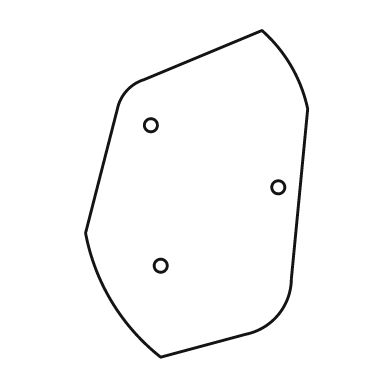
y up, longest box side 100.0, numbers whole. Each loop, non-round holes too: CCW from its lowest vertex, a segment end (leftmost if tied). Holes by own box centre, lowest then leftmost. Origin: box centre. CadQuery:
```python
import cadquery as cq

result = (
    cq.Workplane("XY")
    .moveTo(-11.0, -50.0)
    .lineTo(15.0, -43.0)
    .threePointArc((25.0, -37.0), (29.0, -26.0))
    .lineTo(34.0, 26.0)
    .threePointArc((29.0, 39.0), (20.0, 50.0))
    .lineTo(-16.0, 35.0)
    .threePointArc((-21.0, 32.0), (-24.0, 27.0))
    .lineTo(-34.0, -12.0)
    .threePointArc((-26.0, -33.0), (-11.0, -50.0))
    .close()
    .moveTo(-11.0, -22.0)
    .circle(2.0)
    .moveTo(25.0, 2.0)
    .circle(2.0)
    .moveTo(-14.0, 21.0)
    .circle(2.0)
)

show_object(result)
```